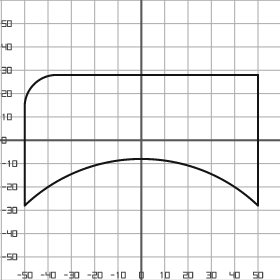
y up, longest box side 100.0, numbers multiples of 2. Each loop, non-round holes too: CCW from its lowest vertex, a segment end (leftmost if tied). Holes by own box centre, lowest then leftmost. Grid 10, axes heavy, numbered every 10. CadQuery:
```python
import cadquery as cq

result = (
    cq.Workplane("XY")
    .moveTo(-50.0, -28.0)
    .threePointArc((0.0, -8.0), (50.0, -28.0))
    .lineTo(50.0, 28.0)
    .lineTo(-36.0, 28.0)
    .threePointArc((-46.0, 24.0), (-50.0, 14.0))
    .close()
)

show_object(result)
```